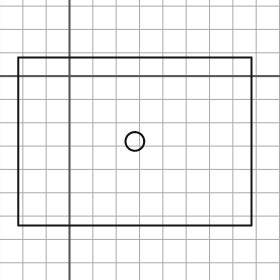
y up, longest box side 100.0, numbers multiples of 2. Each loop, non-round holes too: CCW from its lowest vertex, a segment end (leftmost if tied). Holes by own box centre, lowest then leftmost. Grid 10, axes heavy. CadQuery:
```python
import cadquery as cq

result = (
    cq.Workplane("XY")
    .moveTo(-22.0, -64.0)
    .lineTo(78.0, -64.0)
    .lineTo(78.0, 8.0)
    .lineTo(-22.0, 8.0)
    .close()
    .moveTo(28.0, -28.0)
    .circle(4.0)
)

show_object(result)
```